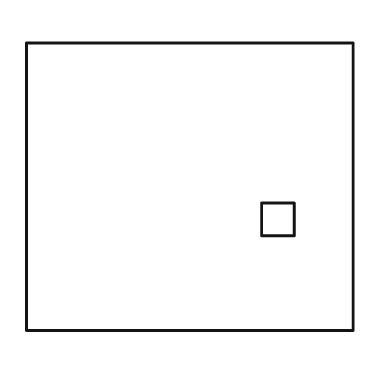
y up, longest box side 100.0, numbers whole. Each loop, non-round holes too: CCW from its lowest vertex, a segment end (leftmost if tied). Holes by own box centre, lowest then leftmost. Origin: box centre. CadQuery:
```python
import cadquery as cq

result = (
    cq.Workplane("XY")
    .moveTo(-50.0, -44.0)
    .lineTo(50.0, -44.0)
    .lineTo(50.0, 44.0)
    .lineTo(-50.0, 44.0)
    .close()
    .moveTo(22.0, -15.0)
    .lineTo(32.0, -15.0)
    .lineTo(32.0, -5.0)
    .lineTo(22.0, -5.0)
    .close()
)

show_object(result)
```